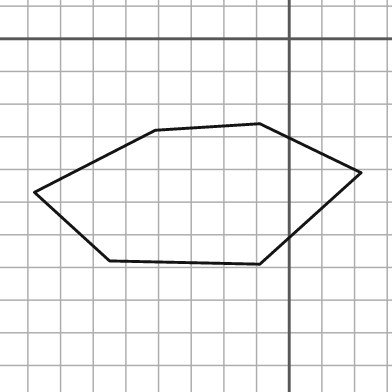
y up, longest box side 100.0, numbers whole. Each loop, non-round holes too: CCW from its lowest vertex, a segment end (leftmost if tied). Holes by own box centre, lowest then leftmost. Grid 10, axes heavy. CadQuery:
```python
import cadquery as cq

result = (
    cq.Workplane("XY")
    .moveTo(-9.0, -69.0)
    .lineTo(22.0, -41.0)
    .lineTo(-9.0, -26.0)
    .lineTo(-41.0, -28.0)
    .lineTo(-78.0, -47.0)
    .lineTo(-55.0, -68.0)
    .close()
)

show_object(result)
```